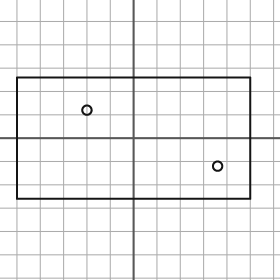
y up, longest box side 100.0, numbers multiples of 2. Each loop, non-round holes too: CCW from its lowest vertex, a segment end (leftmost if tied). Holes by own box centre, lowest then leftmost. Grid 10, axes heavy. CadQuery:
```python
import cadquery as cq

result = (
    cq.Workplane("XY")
    .moveTo(-50.0, -26.0)
    .lineTo(50.0, -26.0)
    .lineTo(50.0, 26.0)
    .lineTo(-50.0, 26.0)
    .close()
    .moveTo(36.0, -12.0)
    .circle(2.0)
    .moveTo(-20.0, 12.0)
    .circle(2.0)
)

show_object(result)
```